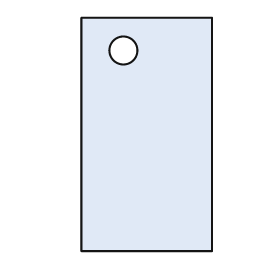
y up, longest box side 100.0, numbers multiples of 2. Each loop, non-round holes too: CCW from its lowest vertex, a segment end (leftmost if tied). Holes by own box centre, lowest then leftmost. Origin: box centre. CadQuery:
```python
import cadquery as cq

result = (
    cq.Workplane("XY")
    .moveTo(-28.0, -50.0)
    .lineTo(28.0, -50.0)
    .lineTo(28.0, 50.0)
    .lineTo(-28.0, 50.0)
    .close()
    .moveTo(-10.0, 36.0)
    .circle(6.0)
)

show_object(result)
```